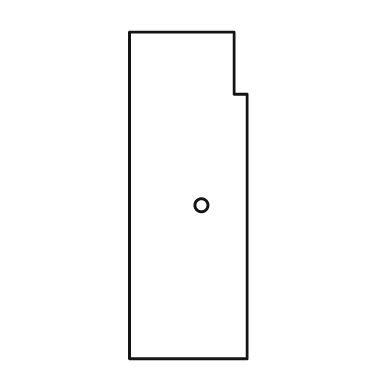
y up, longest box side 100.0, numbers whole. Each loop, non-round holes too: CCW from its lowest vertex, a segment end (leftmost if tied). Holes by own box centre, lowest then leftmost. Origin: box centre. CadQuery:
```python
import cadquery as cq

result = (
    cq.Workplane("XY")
    .moveTo(-18.0, -50.0)
    .lineTo(18.0, -50.0)
    .lineTo(18.0, 31.0)
    .lineTo(14.0, 31.0)
    .lineTo(14.0, 50.0)
    .lineTo(-18.0, 50.0)
    .close()
    .moveTo(4.0, -3.0)
    .circle(2.0)
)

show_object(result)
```